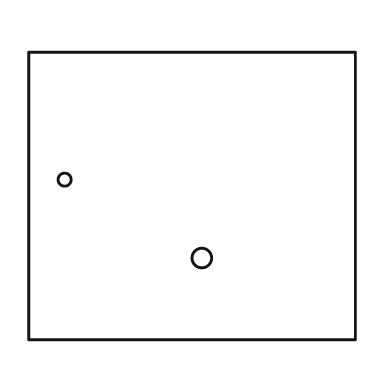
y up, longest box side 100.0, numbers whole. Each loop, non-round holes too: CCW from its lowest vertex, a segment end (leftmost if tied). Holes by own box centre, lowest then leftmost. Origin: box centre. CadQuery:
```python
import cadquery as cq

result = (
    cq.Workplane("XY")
    .moveTo(-50.0, -44.0)
    .lineTo(50.0, -44.0)
    .lineTo(50.0, 44.0)
    .lineTo(-50.0, 44.0)
    .close()
    .moveTo(3.0, -19.0)
    .circle(3.0)
    .moveTo(-39.0, 5.0)
    .circle(2.0)
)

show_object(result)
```